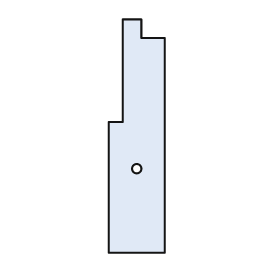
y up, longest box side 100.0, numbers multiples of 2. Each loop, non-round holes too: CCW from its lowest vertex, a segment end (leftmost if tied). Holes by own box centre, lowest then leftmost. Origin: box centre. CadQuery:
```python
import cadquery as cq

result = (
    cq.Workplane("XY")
    .moveTo(-12.0, -50.0)
    .lineTo(12.0, -50.0)
    .lineTo(12.0, 42.0)
    .lineTo(2.0, 42.0)
    .lineTo(2.0, 50.0)
    .lineTo(-6.0, 50.0)
    .lineTo(-6.0, 6.0)
    .lineTo(-12.0, 6.0)
    .close()
    .moveTo(0.0, -14.0)
    .circle(2.0)
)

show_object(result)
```